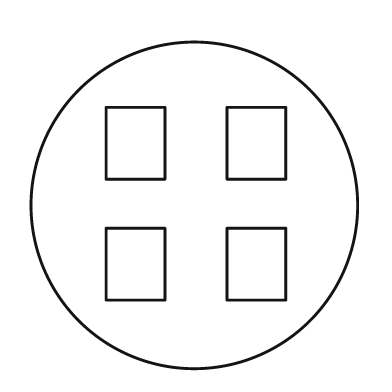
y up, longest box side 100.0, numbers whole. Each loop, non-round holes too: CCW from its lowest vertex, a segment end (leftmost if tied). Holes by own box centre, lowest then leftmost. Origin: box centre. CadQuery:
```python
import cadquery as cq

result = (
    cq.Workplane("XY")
    .moveTo(0.0, 0.0)
    .circle(50.0)
    .moveTo(-27.0, -29.0)
    .lineTo(-9.0, -29.0)
    .lineTo(-9.0, -7.0)
    .lineTo(-27.0, -7.0)
    .close()
    .moveTo(10.0, -29.0)
    .lineTo(28.0, -29.0)
    .lineTo(28.0, -7.0)
    .lineTo(10.0, -7.0)
    .close()
    .moveTo(-27.0, 8.0)
    .lineTo(-9.0, 8.0)
    .lineTo(-9.0, 30.0)
    .lineTo(-27.0, 30.0)
    .close()
    .moveTo(10.0, 8.0)
    .lineTo(28.0, 8.0)
    .lineTo(28.0, 30.0)
    .lineTo(10.0, 30.0)
    .close()
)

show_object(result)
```